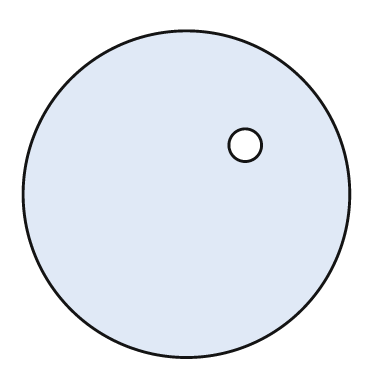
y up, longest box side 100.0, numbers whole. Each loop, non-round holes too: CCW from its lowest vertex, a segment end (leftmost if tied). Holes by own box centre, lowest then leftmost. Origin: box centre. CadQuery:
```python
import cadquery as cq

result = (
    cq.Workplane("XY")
    .moveTo(0.0, 0.0)
    .circle(50.0)
    .moveTo(18.0, 15.0)
    .circle(5.0)
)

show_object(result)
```